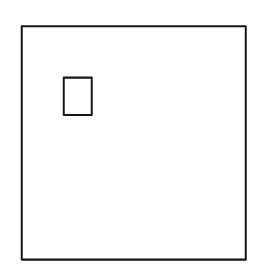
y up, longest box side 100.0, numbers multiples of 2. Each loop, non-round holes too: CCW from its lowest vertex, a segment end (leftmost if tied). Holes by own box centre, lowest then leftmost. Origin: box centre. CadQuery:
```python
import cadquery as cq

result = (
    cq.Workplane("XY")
    .moveTo(-48.0, -50.0)
    .lineTo(48.0, -50.0)
    .lineTo(48.0, 50.0)
    .lineTo(-48.0, 50.0)
    .close()
    .moveTo(-30.0, 12.0)
    .lineTo(-18.0, 12.0)
    .lineTo(-18.0, 28.0)
    .lineTo(-30.0, 28.0)
    .close()
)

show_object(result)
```